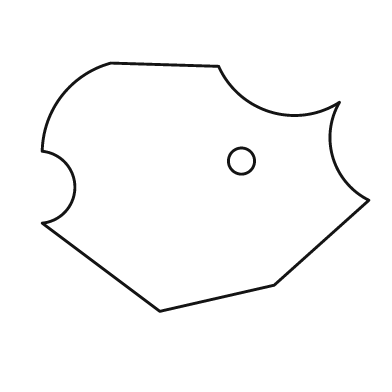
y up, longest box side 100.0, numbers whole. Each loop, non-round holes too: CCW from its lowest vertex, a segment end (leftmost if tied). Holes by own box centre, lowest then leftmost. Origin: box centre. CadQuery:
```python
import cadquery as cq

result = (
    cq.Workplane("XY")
    .moveTo(-14.0, -38.0)
    .lineTo(21.0, -30.0)
    .lineTo(50.0, -4.0)
    .threePointArc((39.0, 9.0), (41.0, 26.0))
    .threePointArc((20.0, 23.0), (4.0, 37.0))
    .lineTo(-29.0, 38.0)
    .threePointArc((-44.0, 28.0), (-50.0, 11.0))
    .threePointArc((-40.0, 0.0), (-50.0, -11.0))
    .close()
    .moveTo(11.0, 8.0)
    .circle(4.0)
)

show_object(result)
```